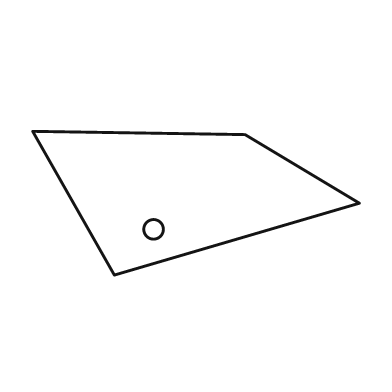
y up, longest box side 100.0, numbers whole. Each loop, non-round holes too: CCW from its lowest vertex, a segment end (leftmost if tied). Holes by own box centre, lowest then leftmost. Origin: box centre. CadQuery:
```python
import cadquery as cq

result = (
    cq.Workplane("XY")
    .moveTo(-25.0, -22.0)
    .lineTo(50.0, 0.0)
    .lineTo(15.0, 21.0)
    .lineTo(-50.0, 22.0)
    .close()
    .moveTo(-13.0, -8.0)
    .circle(3.0)
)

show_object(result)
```